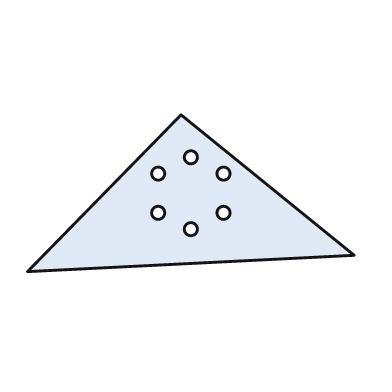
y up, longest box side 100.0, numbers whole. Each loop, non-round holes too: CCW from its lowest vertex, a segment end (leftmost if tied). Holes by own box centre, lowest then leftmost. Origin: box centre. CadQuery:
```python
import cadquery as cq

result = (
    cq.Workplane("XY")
    .moveTo(-50.0, -24.0)
    .lineTo(50.0, -19.0)
    .lineTo(-3.0, 24.0)
    .close()
    .moveTo(0.0, -11.0)
    .circle(2.0)
    .moveTo(-10.0, -6.0)
    .circle(2.0)
    .moveTo(10.0, -6.0)
    .circle(2.0)
    .moveTo(-10.0, 6.0)
    .circle(2.0)
    .moveTo(10.0, 6.0)
    .circle(2.0)
    .moveTo(0.0, 11.0)
    .circle(2.0)
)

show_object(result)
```